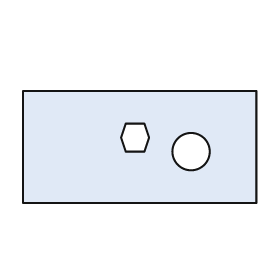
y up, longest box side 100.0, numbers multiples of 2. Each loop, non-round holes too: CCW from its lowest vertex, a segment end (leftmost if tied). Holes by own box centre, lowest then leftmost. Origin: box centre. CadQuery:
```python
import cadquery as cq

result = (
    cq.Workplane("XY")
    .moveTo(-50.0, -24.0)
    .lineTo(50.0, -24.0)
    .lineTo(50.0, 24.0)
    .lineTo(-50.0, 24.0)
    .close()
    .moveTo(22.0, -2.0)
    .circle(8.0)
    .moveTo(-6.0, -2.0)
    .lineTo(2.0, -2.0)
    .lineTo(4.0, 4.0)
    .lineTo(2.0, 10.0)
    .lineTo(-6.0, 10.0)
    .lineTo(-8.0, 4.0)
    .close()
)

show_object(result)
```